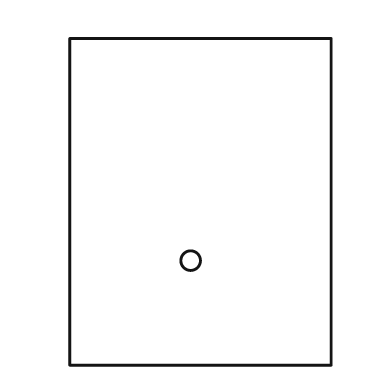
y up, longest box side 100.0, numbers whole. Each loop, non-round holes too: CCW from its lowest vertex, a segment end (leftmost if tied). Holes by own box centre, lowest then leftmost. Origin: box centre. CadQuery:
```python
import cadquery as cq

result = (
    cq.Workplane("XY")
    .moveTo(-40.0, -50.0)
    .lineTo(40.0, -50.0)
    .lineTo(40.0, 50.0)
    .lineTo(-40.0, 50.0)
    .close()
    .moveTo(-3.0, -18.0)
    .circle(3.0)
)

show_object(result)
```